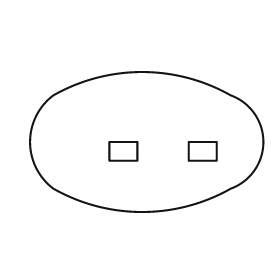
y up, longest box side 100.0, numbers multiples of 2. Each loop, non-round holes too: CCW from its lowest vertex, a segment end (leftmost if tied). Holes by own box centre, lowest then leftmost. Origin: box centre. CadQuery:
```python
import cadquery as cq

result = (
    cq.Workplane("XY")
    .moveTo(-40.0, -20.0)
    .threePointArc((-2.0, -30.0), (36.0, -20.0))
    .threePointArc((50.0, 0.0), (36.0, 20.0))
    .threePointArc((-2.0, 30.0), (-40.0, 20.0))
    .threePointArc((-50.0, 0.0), (-40.0, -20.0))
    .close()
    .moveTo(-16.0, -8.0)
    .lineTo(-4.0, -8.0)
    .lineTo(-4.0, 0.0)
    .lineTo(-16.0, 0.0)
    .close()
    .moveTo(18.0, -8.0)
    .lineTo(30.0, -8.0)
    .lineTo(30.0, 0.0)
    .lineTo(18.0, 0.0)
    .close()
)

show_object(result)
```